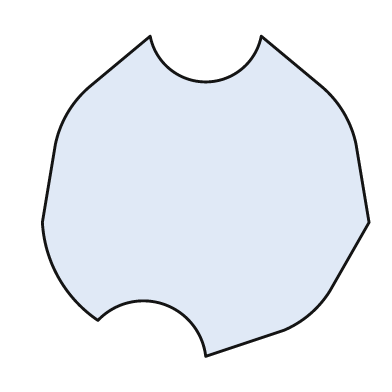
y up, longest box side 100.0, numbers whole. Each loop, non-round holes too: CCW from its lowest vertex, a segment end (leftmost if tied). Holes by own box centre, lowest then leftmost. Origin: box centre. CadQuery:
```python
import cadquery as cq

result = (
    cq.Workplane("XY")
    .moveTo(0.0, -49.0)
    .lineTo(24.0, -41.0)
    .threePointArc((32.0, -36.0), (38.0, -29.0))
    .lineTo(50.0, -8.0)
    .lineTo(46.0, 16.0)
    .threePointArc((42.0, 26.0), (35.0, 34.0))
    .lineTo(17.0, 49.0)
    .threePointArc((0.0, 35.0), (-17.0, 49.0))
    .lineTo(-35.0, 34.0)
    .threePointArc((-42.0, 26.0), (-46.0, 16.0))
    .lineTo(-50.0, -8.0)
    .threePointArc((-45.0, -25.0), (-33.0, -38.0))
    .threePointArc((-13.0, -33.0), (0.0, -49.0))
    .close()
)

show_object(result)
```